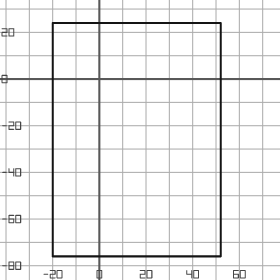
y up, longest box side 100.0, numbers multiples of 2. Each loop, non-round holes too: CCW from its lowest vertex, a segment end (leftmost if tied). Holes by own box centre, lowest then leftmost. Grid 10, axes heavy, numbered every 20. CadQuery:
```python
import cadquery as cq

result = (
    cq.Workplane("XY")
    .moveTo(-20.0, -76.0)
    .lineTo(52.0, -76.0)
    .lineTo(52.0, 24.0)
    .lineTo(-20.0, 24.0)
    .close()
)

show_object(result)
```